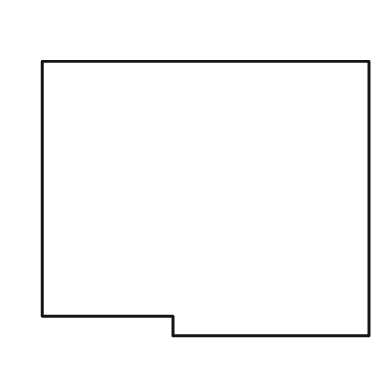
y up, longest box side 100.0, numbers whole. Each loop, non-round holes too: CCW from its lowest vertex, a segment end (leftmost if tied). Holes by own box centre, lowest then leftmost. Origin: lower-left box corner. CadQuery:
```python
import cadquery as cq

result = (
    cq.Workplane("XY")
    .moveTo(40.0, 0.0)
    .lineTo(100.0, 0.0)
    .lineTo(100.0, 84.0)
    .lineTo(0.0, 84.0)
    .lineTo(0.0, 6.0)
    .lineTo(40.0, 6.0)
    .close()
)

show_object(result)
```